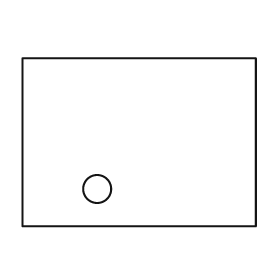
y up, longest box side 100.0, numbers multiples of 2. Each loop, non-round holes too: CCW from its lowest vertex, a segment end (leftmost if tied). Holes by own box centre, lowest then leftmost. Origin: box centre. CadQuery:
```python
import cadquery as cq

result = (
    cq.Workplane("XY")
    .moveTo(-50.0, -36.0)
    .lineTo(50.0, -36.0)
    .lineTo(50.0, 36.0)
    .lineTo(-50.0, 36.0)
    .close()
    .moveTo(-18.0, -20.0)
    .circle(6.0)
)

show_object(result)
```